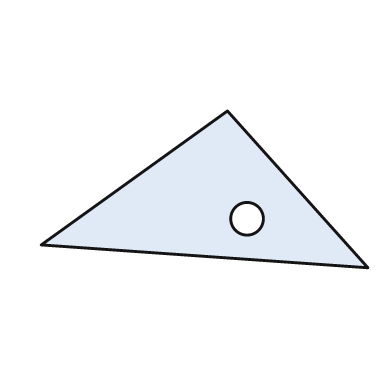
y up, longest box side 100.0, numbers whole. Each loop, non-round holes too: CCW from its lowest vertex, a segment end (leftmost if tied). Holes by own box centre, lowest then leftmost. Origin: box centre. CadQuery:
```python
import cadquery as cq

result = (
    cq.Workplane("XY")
    .moveTo(50.0, -24.0)
    .lineTo(7.0, 24.0)
    .lineTo(-50.0, -17.0)
    .close()
    .moveTo(13.0, -9.0)
    .circle(5.0)
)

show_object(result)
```